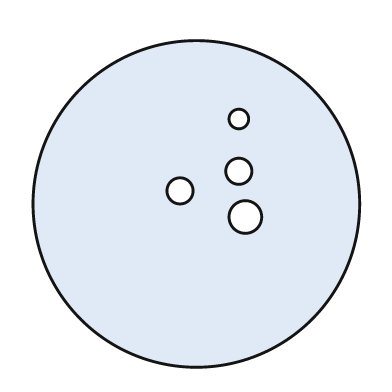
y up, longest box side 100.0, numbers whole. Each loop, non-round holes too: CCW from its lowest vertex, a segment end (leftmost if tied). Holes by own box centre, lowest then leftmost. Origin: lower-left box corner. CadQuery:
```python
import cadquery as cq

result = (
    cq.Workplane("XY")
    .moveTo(50.0, 50.0)
    .circle(50.0)
    .moveTo(65.0, 46.0)
    .circle(5.0)
    .moveTo(45.0, 54.0)
    .circle(4.0)
    .moveTo(63.0, 60.0)
    .circle(4.0)
    .moveTo(63.0, 76.0)
    .circle(3.0)
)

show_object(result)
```